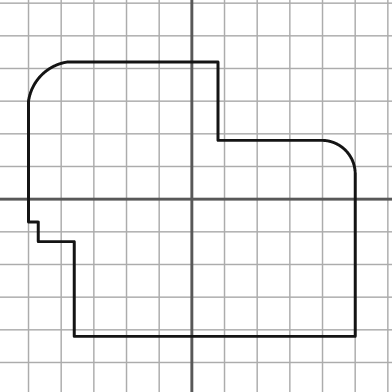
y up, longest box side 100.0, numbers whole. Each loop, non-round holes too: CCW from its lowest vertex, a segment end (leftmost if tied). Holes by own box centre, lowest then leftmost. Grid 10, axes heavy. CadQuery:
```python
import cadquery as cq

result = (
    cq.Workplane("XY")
    .moveTo(-36.0, -42.0)
    .lineTo(50.0, -42.0)
    .lineTo(50.0, 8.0)
    .threePointArc((47.0, 15.0), (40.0, 18.0))
    .lineTo(8.0, 18.0)
    .lineTo(8.0, 42.0)
    .lineTo(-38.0, 42.0)
    .threePointArc((-46.0, 38.0), (-50.0, 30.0))
    .lineTo(-50.0, -7.0)
    .lineTo(-47.0, -7.0)
    .lineTo(-47.0, -13.0)
    .lineTo(-36.0, -13.0)
    .close()
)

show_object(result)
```